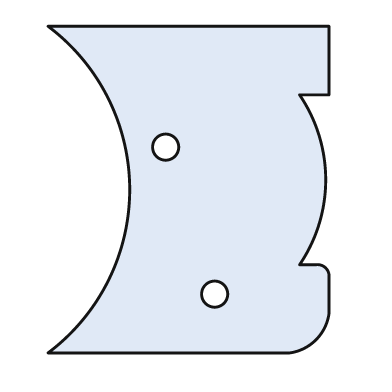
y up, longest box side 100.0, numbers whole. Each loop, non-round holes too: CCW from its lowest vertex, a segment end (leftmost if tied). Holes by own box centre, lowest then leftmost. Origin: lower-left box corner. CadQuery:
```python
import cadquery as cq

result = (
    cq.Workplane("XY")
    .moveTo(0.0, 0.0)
    .lineTo(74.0, 0.0)
    .threePointArc((82.0, 4.0), (86.0, 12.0))
    .lineTo(86.0, 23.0)
    .threePointArc((85.0, 26.0), (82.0, 27.0))
    .lineTo(77.0, 27.0)
    .threePointArc((85.0, 53.0), (77.0, 79.0))
    .lineTo(86.0, 79.0)
    .lineTo(86.0, 100.0)
    .lineTo(0.0, 100.0)
    .threePointArc((25.0, 50.0), (0.0, 0.0))
    .close()
    .moveTo(51.0, 18.0)
    .circle(4.0)
    .moveTo(36.0, 63.0)
    .circle(4.0)
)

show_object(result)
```